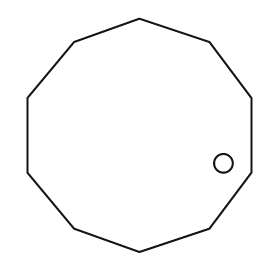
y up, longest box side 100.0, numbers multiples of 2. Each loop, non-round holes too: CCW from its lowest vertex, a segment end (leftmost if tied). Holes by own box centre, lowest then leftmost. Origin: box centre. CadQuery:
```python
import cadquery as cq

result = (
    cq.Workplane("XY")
    .moveTo(0.0, -50.0)
    .lineTo(30.0, -40.0)
    .lineTo(48.0, -16.0)
    .lineTo(48.0, 16.0)
    .lineTo(30.0, 40.0)
    .lineTo(0.0, 50.0)
    .lineTo(-28.0, 40.0)
    .lineTo(-48.0, 16.0)
    .lineTo(-48.0, -16.0)
    .lineTo(-28.0, -40.0)
    .close()
    .moveTo(36.0, -12.0)
    .circle(4.0)
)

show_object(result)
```